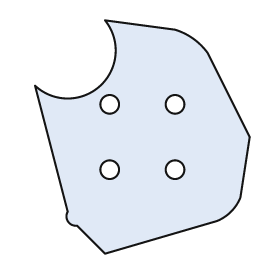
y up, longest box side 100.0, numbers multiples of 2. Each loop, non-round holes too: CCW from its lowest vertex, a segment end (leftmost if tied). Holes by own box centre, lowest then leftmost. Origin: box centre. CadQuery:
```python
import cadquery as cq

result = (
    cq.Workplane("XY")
    .moveTo(-16.0, -50.0)
    .lineTo(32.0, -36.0)
    .threePointArc((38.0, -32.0), (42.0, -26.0))
    .lineTo(46.0, 0.0)
    .lineTo(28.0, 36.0)
    .threePointArc((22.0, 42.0), (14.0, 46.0))
    .lineTo(-16.0, 50.0)
    .threePointArc((-18.0, 22.0), (-46.0, 22.0))
    .lineTo(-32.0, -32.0)
    .threePointArc((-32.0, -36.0), (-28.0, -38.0))
    .close()
    .moveTo(-14.0, -14.0)
    .circle(4.0)
    .moveTo(14.0, -14.0)
    .circle(4.0)
    .moveTo(-14.0, 14.0)
    .circle(4.0)
    .moveTo(14.0, 14.0)
    .circle(4.0)
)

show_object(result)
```